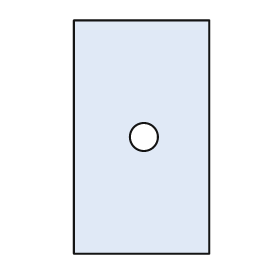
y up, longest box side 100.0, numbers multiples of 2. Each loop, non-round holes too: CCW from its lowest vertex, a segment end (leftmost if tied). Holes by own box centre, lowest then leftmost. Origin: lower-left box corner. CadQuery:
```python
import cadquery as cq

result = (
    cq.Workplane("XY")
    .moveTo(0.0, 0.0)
    .lineTo(58.0, 0.0)
    .lineTo(58.0, 100.0)
    .lineTo(0.0, 100.0)
    .close()
    .moveTo(30.0, 50.0)
    .circle(6.0)
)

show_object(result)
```